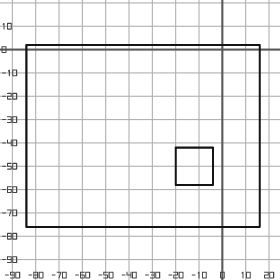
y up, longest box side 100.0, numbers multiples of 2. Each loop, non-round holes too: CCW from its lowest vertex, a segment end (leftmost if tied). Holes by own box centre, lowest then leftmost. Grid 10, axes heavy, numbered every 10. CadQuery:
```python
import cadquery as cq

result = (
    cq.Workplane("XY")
    .moveTo(-84.0, -76.0)
    .lineTo(16.0, -76.0)
    .lineTo(16.0, 2.0)
    .lineTo(-84.0, 2.0)
    .close()
    .moveTo(-20.0, -58.0)
    .lineTo(-4.0, -58.0)
    .lineTo(-4.0, -42.0)
    .lineTo(-20.0, -42.0)
    .close()
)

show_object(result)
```